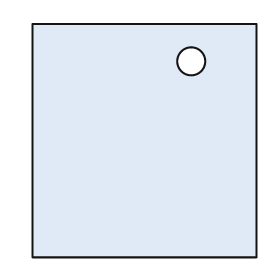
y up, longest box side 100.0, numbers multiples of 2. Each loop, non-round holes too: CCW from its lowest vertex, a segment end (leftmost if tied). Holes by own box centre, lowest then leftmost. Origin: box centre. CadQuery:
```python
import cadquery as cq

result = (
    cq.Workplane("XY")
    .moveTo(-48.0, -50.0)
    .lineTo(48.0, -50.0)
    .lineTo(48.0, 50.0)
    .lineTo(-48.0, 50.0)
    .close()
    .moveTo(20.0, 34.0)
    .circle(6.0)
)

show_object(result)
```